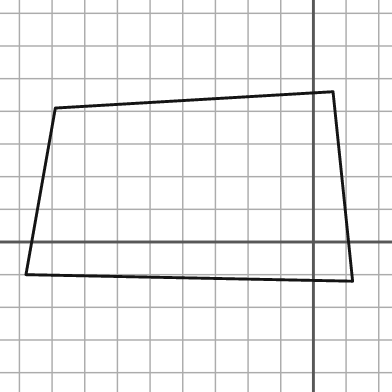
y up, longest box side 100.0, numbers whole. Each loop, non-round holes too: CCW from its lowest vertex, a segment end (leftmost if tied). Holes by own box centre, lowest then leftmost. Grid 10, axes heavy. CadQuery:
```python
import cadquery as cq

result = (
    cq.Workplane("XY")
    .moveTo(12.0, -12.0)
    .lineTo(6.0, 46.0)
    .lineTo(-79.0, 41.0)
    .lineTo(-88.0, -10.0)
    .close()
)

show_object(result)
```